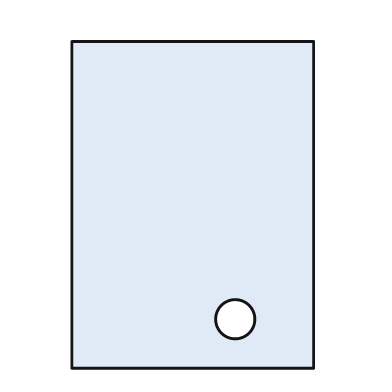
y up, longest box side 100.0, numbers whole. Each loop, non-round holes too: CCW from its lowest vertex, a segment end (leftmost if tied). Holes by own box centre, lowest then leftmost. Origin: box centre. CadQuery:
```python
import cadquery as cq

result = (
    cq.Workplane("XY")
    .moveTo(-37.0, -50.0)
    .lineTo(37.0, -50.0)
    .lineTo(37.0, 50.0)
    .lineTo(-37.0, 50.0)
    .close()
    .moveTo(13.0, -35.0)
    .circle(6.0)
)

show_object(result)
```